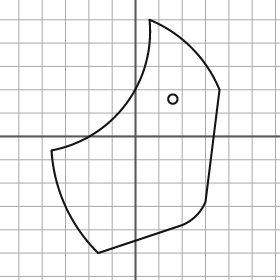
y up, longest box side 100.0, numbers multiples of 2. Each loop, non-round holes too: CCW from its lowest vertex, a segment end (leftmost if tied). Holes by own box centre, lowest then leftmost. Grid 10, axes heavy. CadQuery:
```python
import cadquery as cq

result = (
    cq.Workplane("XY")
    .moveTo(-16.0, -50.0)
    .lineTo(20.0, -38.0)
    .threePointArc((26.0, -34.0), (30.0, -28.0))
    .lineTo(36.0, 20.0)
    .threePointArc((24.0, 38.0), (6.0, 50.0))
    .threePointArc((-4.0, 14.0), (-36.0, -6.0))
    .threePointArc((-30.0, -30.0), (-16.0, -50.0))
    .close()
    .moveTo(16.0, 16.0)
    .circle(2.0)
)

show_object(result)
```